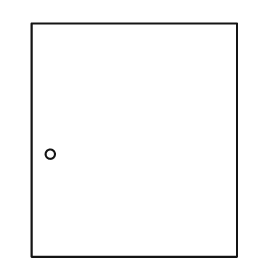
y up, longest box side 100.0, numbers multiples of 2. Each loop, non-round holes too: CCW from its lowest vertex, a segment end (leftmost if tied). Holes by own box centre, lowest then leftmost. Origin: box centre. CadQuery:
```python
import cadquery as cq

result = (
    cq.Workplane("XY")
    .moveTo(-44.0, -50.0)
    .lineTo(44.0, -50.0)
    .lineTo(44.0, 50.0)
    .lineTo(-44.0, 50.0)
    .close()
    .moveTo(-36.0, -6.0)
    .circle(2.0)
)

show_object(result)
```